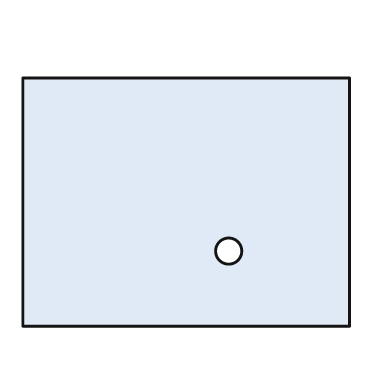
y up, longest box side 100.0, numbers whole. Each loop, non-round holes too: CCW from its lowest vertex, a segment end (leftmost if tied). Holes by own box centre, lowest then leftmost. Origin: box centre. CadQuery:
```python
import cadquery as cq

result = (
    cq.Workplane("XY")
    .moveTo(-50.0, -38.0)
    .lineTo(50.0, -38.0)
    .lineTo(50.0, 38.0)
    .lineTo(-50.0, 38.0)
    .close()
    .moveTo(13.0, -15.0)
    .circle(4.0)
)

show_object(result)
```